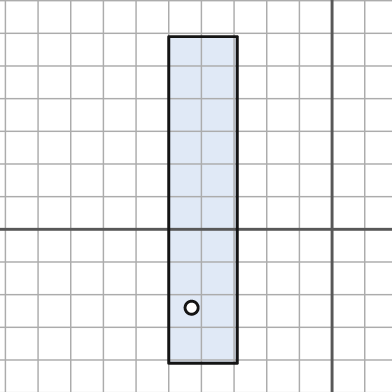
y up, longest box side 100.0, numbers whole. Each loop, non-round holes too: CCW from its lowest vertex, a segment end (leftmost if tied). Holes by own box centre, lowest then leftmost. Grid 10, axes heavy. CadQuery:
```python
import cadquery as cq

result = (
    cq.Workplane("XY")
    .moveTo(-50.0, -41.0)
    .lineTo(-29.0, -41.0)
    .lineTo(-29.0, 59.0)
    .lineTo(-50.0, 59.0)
    .close()
    .moveTo(-43.0, -24.0)
    .circle(2.0)
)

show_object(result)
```